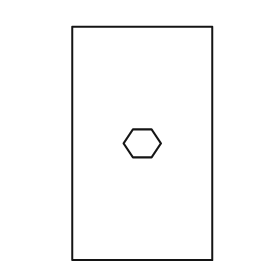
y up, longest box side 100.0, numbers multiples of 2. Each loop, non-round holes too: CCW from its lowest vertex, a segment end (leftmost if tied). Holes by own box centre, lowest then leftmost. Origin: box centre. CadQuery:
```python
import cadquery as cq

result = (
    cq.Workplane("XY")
    .moveTo(-30.0, -50.0)
    .lineTo(30.0, -50.0)
    .lineTo(30.0, 50.0)
    .lineTo(-30.0, 50.0)
    .close()
    .moveTo(-4.0, -6.0)
    .lineTo(4.0, -6.0)
    .lineTo(8.0, 0.0)
    .lineTo(4.0, 6.0)
    .lineTo(-4.0, 6.0)
    .lineTo(-8.0, 0.0)
    .close()
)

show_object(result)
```